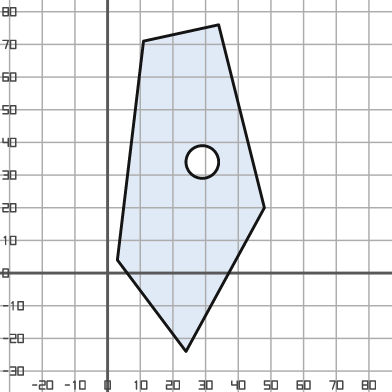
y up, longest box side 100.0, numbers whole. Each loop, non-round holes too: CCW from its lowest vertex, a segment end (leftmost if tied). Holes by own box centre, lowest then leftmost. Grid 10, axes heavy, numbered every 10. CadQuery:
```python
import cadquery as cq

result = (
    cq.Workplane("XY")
    .moveTo(24.0, -24.0)
    .lineTo(48.0, 20.0)
    .lineTo(34.0, 76.0)
    .lineTo(11.0, 71.0)
    .lineTo(3.0, 4.0)
    .close()
    .moveTo(29.0, 34.0)
    .circle(5.0)
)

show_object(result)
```